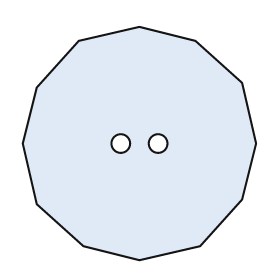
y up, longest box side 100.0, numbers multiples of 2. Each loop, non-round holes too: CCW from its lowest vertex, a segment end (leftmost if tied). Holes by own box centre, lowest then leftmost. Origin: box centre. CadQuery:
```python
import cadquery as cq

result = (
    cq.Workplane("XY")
    .moveTo(0.0, -50.0)
    .lineTo(26.0, -44.0)
    .lineTo(44.0, -24.0)
    .lineTo(50.0, 0.0)
    .lineTo(44.0, 26.0)
    .lineTo(24.0, 44.0)
    .lineTo(0.0, 50.0)
    .lineTo(-26.0, 44.0)
    .lineTo(-44.0, 24.0)
    .lineTo(-50.0, 0.0)
    .lineTo(-44.0, -26.0)
    .lineTo(-24.0, -44.0)
    .close()
    .moveTo(-8.0, 0.0)
    .circle(4.0)
    .moveTo(8.0, 0.0)
    .circle(4.0)
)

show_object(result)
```